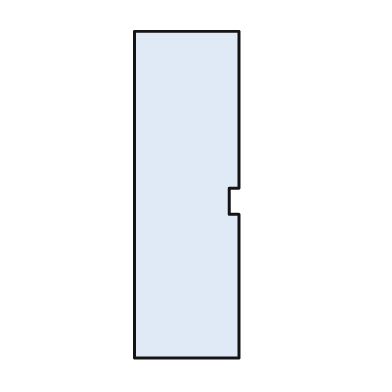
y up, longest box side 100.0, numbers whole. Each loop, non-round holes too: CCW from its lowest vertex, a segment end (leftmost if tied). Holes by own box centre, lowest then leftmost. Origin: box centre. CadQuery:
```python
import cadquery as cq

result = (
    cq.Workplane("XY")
    .moveTo(-16.0, -50.0)
    .lineTo(16.0, -50.0)
    .lineTo(16.0, -6.0)
    .lineTo(13.0, -6.0)
    .lineTo(13.0, 2.0)
    .lineTo(16.0, 2.0)
    .lineTo(16.0, 50.0)
    .lineTo(-16.0, 50.0)
    .close()
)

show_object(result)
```